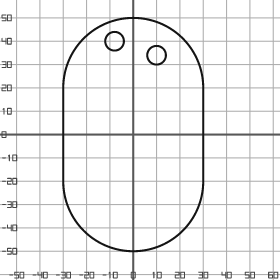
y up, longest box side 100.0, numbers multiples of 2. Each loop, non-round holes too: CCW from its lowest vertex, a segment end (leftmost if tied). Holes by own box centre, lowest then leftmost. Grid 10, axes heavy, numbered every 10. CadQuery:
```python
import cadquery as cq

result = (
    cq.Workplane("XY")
    .moveTo(-30.0, -20.0)
    .threePointArc((0.0, -50.0), (30.0, -20.0))
    .lineTo(30.0, 20.0)
    .threePointArc((0.0, 50.0), (-30.0, 20.0))
    .close()
    .moveTo(10.0, 34.0)
    .circle(4.0)
    .moveTo(-8.0, 40.0)
    .circle(4.0)
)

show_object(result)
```